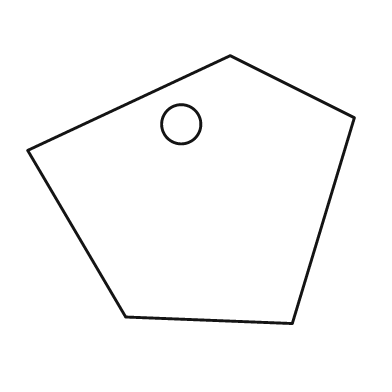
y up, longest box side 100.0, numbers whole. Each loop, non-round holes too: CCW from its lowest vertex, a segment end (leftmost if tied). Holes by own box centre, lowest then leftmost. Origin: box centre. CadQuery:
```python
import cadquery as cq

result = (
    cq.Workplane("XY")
    .moveTo(31.0, -41.0)
    .lineTo(50.0, 22.0)
    .lineTo(12.0, 41.0)
    .lineTo(-50.0, 12.0)
    .lineTo(-20.0, -39.0)
    .close()
    .moveTo(-3.0, 20.0)
    .circle(6.0)
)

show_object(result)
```